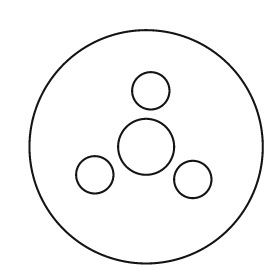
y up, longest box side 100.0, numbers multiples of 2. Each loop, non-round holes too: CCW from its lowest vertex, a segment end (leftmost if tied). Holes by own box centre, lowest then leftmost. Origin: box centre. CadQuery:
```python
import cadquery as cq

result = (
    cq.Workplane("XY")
    .moveTo(0.0, 0.0)
    .circle(50.0)
    .moveTo(20.0, -14.0)
    .circle(8.0)
    .moveTo(-22.0, -12.0)
    .circle(8.0)
    .moveTo(0.0, 0.0)
    .circle(12.0)
    .moveTo(2.0, 24.0)
    .circle(8.0)
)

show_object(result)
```